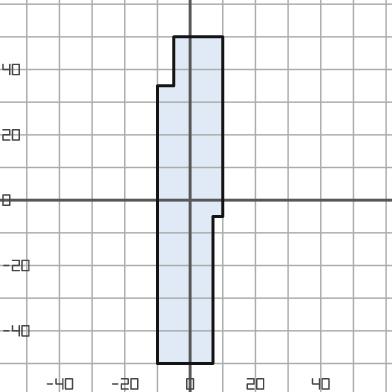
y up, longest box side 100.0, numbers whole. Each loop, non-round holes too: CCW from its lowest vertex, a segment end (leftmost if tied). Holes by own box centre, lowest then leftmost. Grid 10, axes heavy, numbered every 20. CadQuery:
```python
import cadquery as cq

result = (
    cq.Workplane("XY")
    .moveTo(-10.0, -50.0)
    .lineTo(7.0, -50.0)
    .lineTo(7.0, -5.0)
    .lineTo(10.0, -5.0)
    .lineTo(10.0, 50.0)
    .lineTo(-5.0, 50.0)
    .lineTo(-5.0, 35.0)
    .lineTo(-10.0, 35.0)
    .close()
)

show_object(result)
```